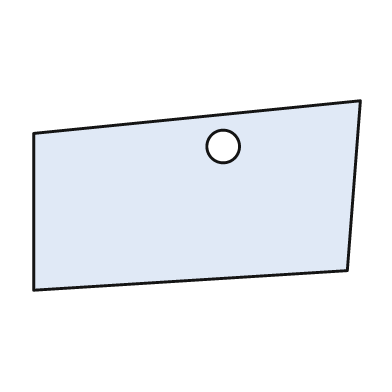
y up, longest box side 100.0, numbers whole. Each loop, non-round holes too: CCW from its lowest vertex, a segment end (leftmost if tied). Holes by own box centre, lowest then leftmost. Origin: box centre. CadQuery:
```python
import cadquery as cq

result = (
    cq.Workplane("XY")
    .moveTo(-50.0, -29.0)
    .lineTo(46.0, -23.0)
    .lineTo(50.0, 29.0)
    .lineTo(-50.0, 19.0)
    .close()
    .moveTo(8.0, 15.0)
    .circle(5.0)
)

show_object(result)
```